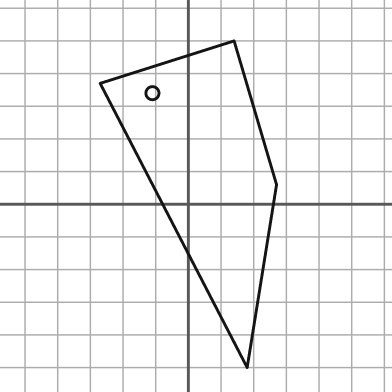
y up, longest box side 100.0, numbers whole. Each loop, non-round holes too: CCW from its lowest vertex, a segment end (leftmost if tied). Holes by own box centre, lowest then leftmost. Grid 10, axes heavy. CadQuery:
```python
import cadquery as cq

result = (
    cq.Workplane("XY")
    .moveTo(18.0, -50.0)
    .lineTo(27.0, 6.0)
    .lineTo(14.0, 50.0)
    .lineTo(-27.0, 37.0)
    .close()
    .moveTo(-11.0, 34.0)
    .circle(2.0)
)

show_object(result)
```